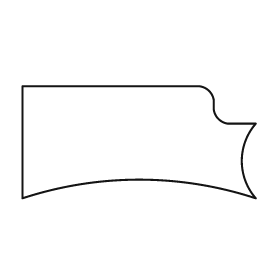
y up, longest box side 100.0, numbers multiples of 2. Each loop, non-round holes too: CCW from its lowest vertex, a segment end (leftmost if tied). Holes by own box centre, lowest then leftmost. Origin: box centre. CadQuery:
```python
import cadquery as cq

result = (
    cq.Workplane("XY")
    .moveTo(-50.0, -24.0)
    .threePointArc((0.0, -16.0), (50.0, -24.0))
    .threePointArc((44.0, -8.0), (50.0, 8.0))
    .lineTo(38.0, 8.0)
    .threePointArc((34.0, 10.0), (32.0, 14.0))
    .lineTo(32.0, 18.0)
    .threePointArc((30.0, 22.0), (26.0, 24.0))
    .lineTo(-50.0, 24.0)
    .close()
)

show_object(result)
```